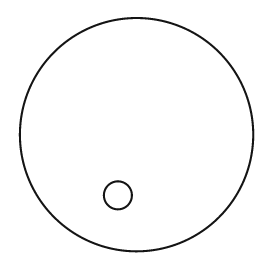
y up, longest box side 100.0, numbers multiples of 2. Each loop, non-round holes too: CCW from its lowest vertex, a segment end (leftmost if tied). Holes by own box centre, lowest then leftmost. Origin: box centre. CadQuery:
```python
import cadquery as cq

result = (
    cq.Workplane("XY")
    .moveTo(0.0, 0.0)
    .circle(50.0)
    .moveTo(-8.0, -26.0)
    .circle(6.0)
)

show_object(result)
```